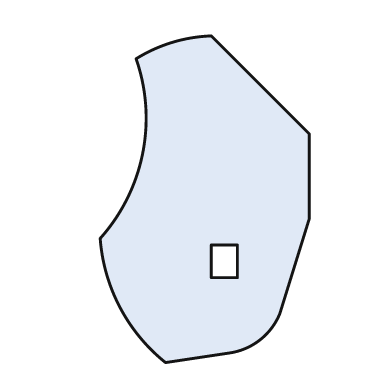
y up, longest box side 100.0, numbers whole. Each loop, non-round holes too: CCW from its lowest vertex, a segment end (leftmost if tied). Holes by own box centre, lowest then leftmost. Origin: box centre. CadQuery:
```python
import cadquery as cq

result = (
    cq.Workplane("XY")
    .moveTo(-12.0, -50.0)
    .lineTo(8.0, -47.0)
    .threePointArc((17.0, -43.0), (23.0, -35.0))
    .lineTo(32.0, -6.0)
    .lineTo(32.0, 20.0)
    .lineTo(2.0, 50.0)
    .threePointArc((-10.0, 48.0), (-21.0, 43.0))
    .threePointArc((-19.0, 14.0), (-32.0, -12.0))
    .threePointArc((-26.0, -33.0), (-12.0, -50.0))
    .close()
    .moveTo(2.0, -24.0)
    .lineTo(10.0, -24.0)
    .lineTo(10.0, -14.0)
    .lineTo(2.0, -14.0)
    .close()
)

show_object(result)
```